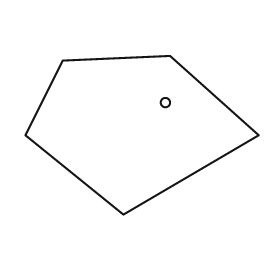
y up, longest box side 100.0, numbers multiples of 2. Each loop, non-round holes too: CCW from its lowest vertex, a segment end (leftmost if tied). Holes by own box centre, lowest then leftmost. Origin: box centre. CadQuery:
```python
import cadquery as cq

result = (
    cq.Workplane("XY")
    .moveTo(-8.0, -34.0)
    .lineTo(50.0, 0.0)
    .lineTo(12.0, 34.0)
    .lineTo(-34.0, 32.0)
    .lineTo(-50.0, 0.0)
    .close()
    .moveTo(10.0, 14.0)
    .circle(2.0)
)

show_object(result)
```